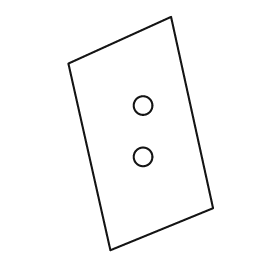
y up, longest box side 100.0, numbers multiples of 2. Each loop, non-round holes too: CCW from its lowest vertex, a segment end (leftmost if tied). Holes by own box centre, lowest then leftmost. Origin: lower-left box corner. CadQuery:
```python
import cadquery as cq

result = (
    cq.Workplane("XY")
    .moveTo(18.0, 0.0)
    .lineTo(62.0, 18.0)
    .lineTo(44.0, 100.0)
    .lineTo(0.0, 80.0)
    .close()
    .moveTo(32.0, 40.0)
    .circle(4.0)
    .moveTo(32.0, 62.0)
    .circle(4.0)
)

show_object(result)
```